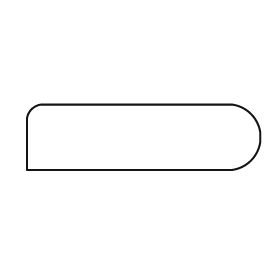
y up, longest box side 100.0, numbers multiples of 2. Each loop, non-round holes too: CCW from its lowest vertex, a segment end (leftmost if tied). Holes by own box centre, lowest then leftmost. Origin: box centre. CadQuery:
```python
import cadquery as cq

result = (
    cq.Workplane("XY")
    .moveTo(-50.0, -14.0)
    .lineTo(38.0, -14.0)
    .threePointArc((46.0, -10.0), (50.0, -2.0))
    .lineTo(50.0, 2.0)
    .threePointArc((46.0, 10.0), (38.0, 14.0))
    .lineTo(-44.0, 14.0)
    .threePointArc((-48.0, 12.0), (-50.0, 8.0))
    .close()
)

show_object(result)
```